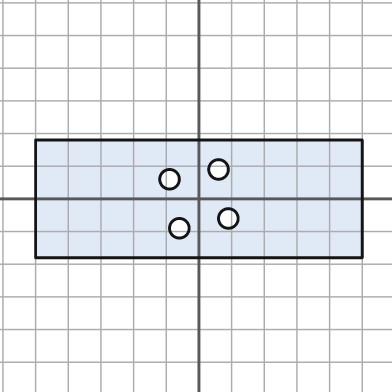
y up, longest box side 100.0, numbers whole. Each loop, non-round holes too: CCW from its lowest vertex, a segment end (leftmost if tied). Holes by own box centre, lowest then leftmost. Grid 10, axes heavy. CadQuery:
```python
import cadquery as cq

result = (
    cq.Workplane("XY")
    .moveTo(-50.0, -18.0)
    .lineTo(50.0, -18.0)
    .lineTo(50.0, 18.0)
    .lineTo(-50.0, 18.0)
    .close()
    .moveTo(-6.0, -9.0)
    .circle(3.0)
    .moveTo(9.0, -6.0)
    .circle(3.0)
    .moveTo(-9.0, 6.0)
    .circle(3.0)
    .moveTo(6.0, 9.0)
    .circle(3.0)
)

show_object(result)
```